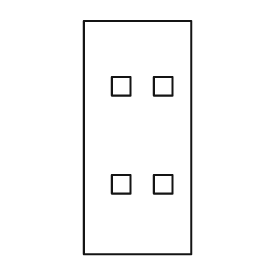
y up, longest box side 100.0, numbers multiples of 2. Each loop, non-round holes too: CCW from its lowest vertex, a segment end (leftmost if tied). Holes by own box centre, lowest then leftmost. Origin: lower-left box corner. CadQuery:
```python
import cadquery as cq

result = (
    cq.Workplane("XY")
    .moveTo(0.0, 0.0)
    .lineTo(46.0, 0.0)
    .lineTo(46.0, 100.0)
    .lineTo(0.0, 100.0)
    .close()
    .moveTo(12.0, 26.0)
    .lineTo(20.0, 26.0)
    .lineTo(20.0, 34.0)
    .lineTo(12.0, 34.0)
    .close()
    .moveTo(30.0, 26.0)
    .lineTo(38.0, 26.0)
    .lineTo(38.0, 34.0)
    .lineTo(30.0, 34.0)
    .close()
    .moveTo(12.0, 68.0)
    .lineTo(20.0, 68.0)
    .lineTo(20.0, 76.0)
    .lineTo(12.0, 76.0)
    .close()
    .moveTo(30.0, 68.0)
    .lineTo(38.0, 68.0)
    .lineTo(38.0, 76.0)
    .lineTo(30.0, 76.0)
    .close()
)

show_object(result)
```